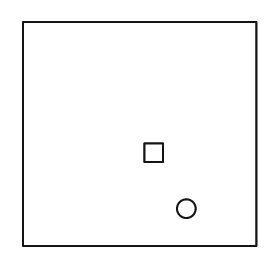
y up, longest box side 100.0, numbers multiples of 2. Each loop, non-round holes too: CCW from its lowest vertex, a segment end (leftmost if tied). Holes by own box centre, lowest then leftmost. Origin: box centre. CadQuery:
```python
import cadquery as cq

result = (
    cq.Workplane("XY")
    .moveTo(-50.0, -48.0)
    .lineTo(50.0, -48.0)
    .lineTo(50.0, 48.0)
    .lineTo(-50.0, 48.0)
    .close()
    .moveTo(20.0, -32.0)
    .circle(4.0)
    .moveTo(2.0, -12.0)
    .lineTo(10.0, -12.0)
    .lineTo(10.0, -4.0)
    .lineTo(2.0, -4.0)
    .close()
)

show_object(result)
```